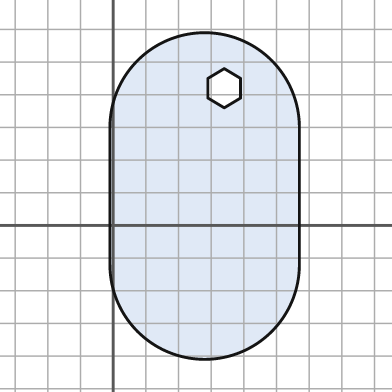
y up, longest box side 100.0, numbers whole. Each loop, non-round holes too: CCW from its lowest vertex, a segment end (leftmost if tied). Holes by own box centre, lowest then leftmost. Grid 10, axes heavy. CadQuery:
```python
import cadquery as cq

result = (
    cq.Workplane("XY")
    .moveTo(-1.0, -12.0)
    .threePointArc((28.0, -41.0), (57.0, -12.0))
    .lineTo(57.0, 30.0)
    .threePointArc((28.0, 59.0), (-1.0, 30.0))
    .close()
    .moveTo(34.0, 36.0)
    .lineTo(39.0, 39.0)
    .lineTo(39.0, 45.0)
    .lineTo(34.0, 48.0)
    .lineTo(29.0, 45.0)
    .lineTo(29.0, 39.0)
    .close()
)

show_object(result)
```